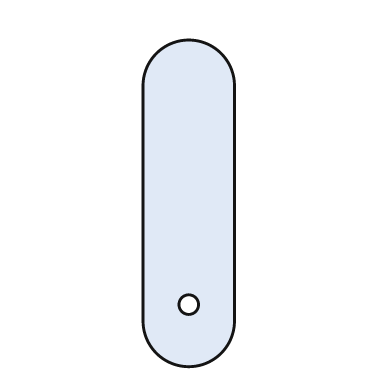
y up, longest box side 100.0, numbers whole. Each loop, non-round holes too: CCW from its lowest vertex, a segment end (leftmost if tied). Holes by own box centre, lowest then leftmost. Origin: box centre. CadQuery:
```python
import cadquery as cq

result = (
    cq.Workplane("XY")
    .moveTo(-14.0, -36.0)
    .threePointArc((0.0, -50.0), (14.0, -36.0))
    .lineTo(14.0, 36.0)
    .threePointArc((0.0, 50.0), (-14.0, 36.0))
    .close()
    .moveTo(0.0, -31.0)
    .circle(3.0)
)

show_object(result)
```